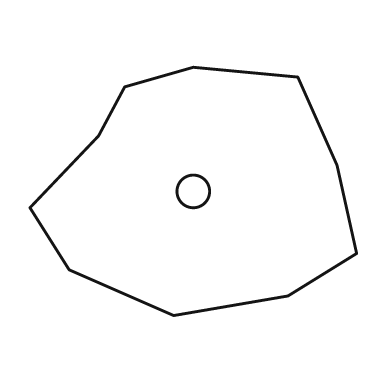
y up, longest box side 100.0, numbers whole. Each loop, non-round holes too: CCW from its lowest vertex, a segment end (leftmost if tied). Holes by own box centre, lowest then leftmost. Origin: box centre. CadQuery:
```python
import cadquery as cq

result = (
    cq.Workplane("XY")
    .moveTo(-6.0, -38.0)
    .lineTo(29.0, -32.0)
    .lineTo(50.0, -19.0)
    .lineTo(44.0, 8.0)
    .lineTo(32.0, 35.0)
    .lineTo(0.0, 38.0)
    .lineTo(-21.0, 32.0)
    .lineTo(-29.0, 17.0)
    .lineTo(-50.0, -5.0)
    .lineTo(-38.0, -24.0)
    .close()
    .moveTo(0.0, 0.0)
    .circle(5.0)
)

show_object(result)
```